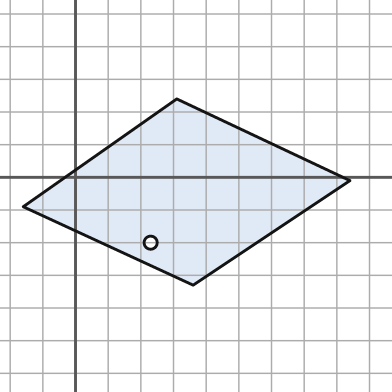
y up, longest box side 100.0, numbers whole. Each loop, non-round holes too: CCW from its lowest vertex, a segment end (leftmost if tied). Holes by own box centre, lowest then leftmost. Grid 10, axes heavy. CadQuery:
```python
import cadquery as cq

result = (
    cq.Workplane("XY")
    .moveTo(36.0, -33.0)
    .lineTo(84.0, -1.0)
    .lineTo(31.0, 24.0)
    .lineTo(-16.0, -9.0)
    .close()
    .moveTo(23.0, -20.0)
    .circle(2.0)
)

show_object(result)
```